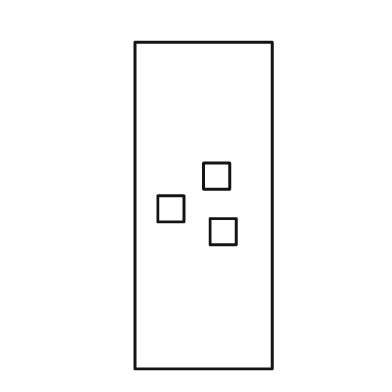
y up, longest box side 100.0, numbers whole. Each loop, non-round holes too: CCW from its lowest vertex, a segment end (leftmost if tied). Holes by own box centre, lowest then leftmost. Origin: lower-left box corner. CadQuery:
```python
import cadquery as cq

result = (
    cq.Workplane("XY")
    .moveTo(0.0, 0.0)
    .lineTo(42.0, 0.0)
    .lineTo(42.0, 100.0)
    .lineTo(0.0, 100.0)
    .close()
    .moveTo(23.0, 38.0)
    .lineTo(31.0, 38.0)
    .lineTo(31.0, 46.0)
    .lineTo(23.0, 46.0)
    .close()
    .moveTo(7.0, 45.0)
    .lineTo(15.0, 45.0)
    .lineTo(15.0, 53.0)
    .lineTo(7.0, 53.0)
    .close()
    .moveTo(21.0, 55.0)
    .lineTo(29.0, 55.0)
    .lineTo(29.0, 63.0)
    .lineTo(21.0, 63.0)
    .close()
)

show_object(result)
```